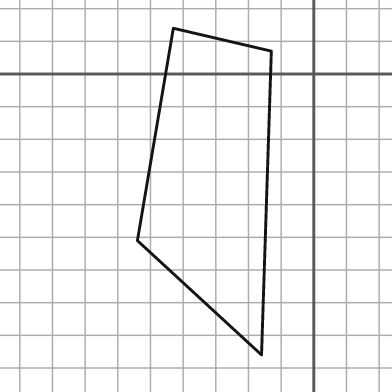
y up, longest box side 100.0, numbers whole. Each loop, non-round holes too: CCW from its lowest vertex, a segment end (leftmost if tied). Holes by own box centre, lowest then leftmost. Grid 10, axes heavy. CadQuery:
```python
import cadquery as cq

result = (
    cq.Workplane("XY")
    .moveTo(-16.0, -86.0)
    .lineTo(-13.0, 7.0)
    .lineTo(-43.0, 14.0)
    .lineTo(-54.0, -51.0)
    .close()
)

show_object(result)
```